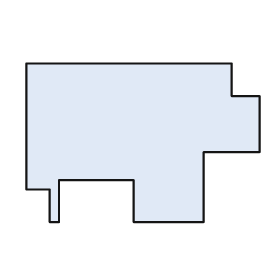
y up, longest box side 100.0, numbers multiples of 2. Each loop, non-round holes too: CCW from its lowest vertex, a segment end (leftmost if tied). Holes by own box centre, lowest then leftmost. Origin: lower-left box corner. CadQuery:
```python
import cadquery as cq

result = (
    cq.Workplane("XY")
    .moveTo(10.0, 0.0)
    .lineTo(14.0, 0.0)
    .lineTo(14.0, 18.0)
    .lineTo(46.0, 18.0)
    .lineTo(46.0, 0.0)
    .lineTo(76.0, 0.0)
    .lineTo(76.0, 30.0)
    .lineTo(100.0, 30.0)
    .lineTo(100.0, 54.0)
    .lineTo(88.0, 54.0)
    .lineTo(88.0, 68.0)
    .lineTo(0.0, 68.0)
    .lineTo(0.0, 14.0)
    .lineTo(10.0, 14.0)
    .close()
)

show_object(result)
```